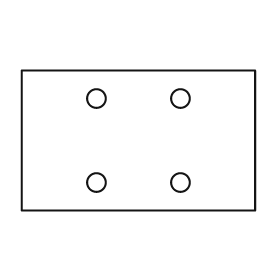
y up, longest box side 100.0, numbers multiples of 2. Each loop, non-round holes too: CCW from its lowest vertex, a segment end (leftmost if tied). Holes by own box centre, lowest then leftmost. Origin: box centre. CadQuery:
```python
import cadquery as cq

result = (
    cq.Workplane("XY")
    .moveTo(-50.0, -30.0)
    .lineTo(50.0, -30.0)
    .lineTo(50.0, 30.0)
    .lineTo(-50.0, 30.0)
    .close()
    .moveTo(-18.0, -18.0)
    .circle(4.0)
    .moveTo(18.0, -18.0)
    .circle(4.0)
    .moveTo(-18.0, 18.0)
    .circle(4.0)
    .moveTo(18.0, 18.0)
    .circle(4.0)
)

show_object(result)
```